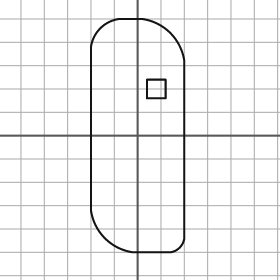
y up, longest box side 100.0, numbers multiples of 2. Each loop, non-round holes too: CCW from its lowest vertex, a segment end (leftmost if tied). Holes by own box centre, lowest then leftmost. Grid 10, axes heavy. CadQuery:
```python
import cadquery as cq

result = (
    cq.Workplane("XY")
    .moveTo(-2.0, -50.0)
    .lineTo(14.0, -50.0)
    .threePointArc((18.0, -48.0), (20.0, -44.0))
    .lineTo(20.0, 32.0)
    .threePointArc((14.0, 44.0), (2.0, 50.0))
    .lineTo(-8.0, 50.0)
    .threePointArc((-16.0, 46.0), (-20.0, 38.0))
    .lineTo(-20.0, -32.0)
    .threePointArc((-14.0, -44.0), (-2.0, -50.0))
    .close()
    .moveTo(4.0, 16.0)
    .lineTo(12.0, 16.0)
    .lineTo(12.0, 24.0)
    .lineTo(4.0, 24.0)
    .close()
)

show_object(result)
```